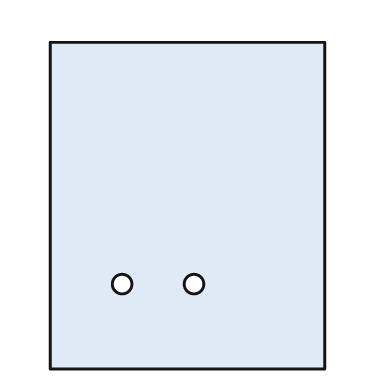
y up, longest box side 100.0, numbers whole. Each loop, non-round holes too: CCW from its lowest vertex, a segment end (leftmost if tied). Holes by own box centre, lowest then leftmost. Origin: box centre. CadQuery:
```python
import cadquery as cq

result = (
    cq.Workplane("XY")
    .moveTo(-42.0, -50.0)
    .lineTo(42.0, -50.0)
    .lineTo(42.0, 50.0)
    .lineTo(-42.0, 50.0)
    .close()
    .moveTo(-20.0, -24.0)
    .circle(3.0)
    .moveTo(2.0, -24.0)
    .circle(3.0)
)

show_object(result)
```